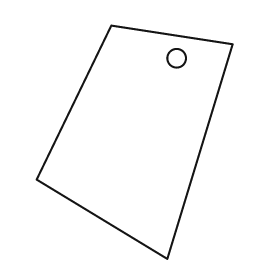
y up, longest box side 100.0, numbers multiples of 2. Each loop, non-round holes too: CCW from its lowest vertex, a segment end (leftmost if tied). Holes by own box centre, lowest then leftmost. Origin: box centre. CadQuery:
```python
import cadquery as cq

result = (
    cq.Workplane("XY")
    .moveTo(14.0, -50.0)
    .lineTo(42.0, 42.0)
    .lineTo(-10.0, 50.0)
    .lineTo(-42.0, -16.0)
    .close()
    .moveTo(18.0, 36.0)
    .circle(4.0)
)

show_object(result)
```